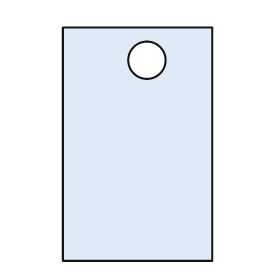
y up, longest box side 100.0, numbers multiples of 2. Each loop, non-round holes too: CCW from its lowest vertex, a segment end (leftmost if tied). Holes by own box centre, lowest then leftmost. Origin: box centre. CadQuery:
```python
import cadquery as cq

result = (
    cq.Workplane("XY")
    .moveTo(-32.0, -50.0)
    .lineTo(32.0, -50.0)
    .lineTo(32.0, 50.0)
    .lineTo(-32.0, 50.0)
    .close()
    .moveTo(4.0, 36.0)
    .circle(8.0)
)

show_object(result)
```